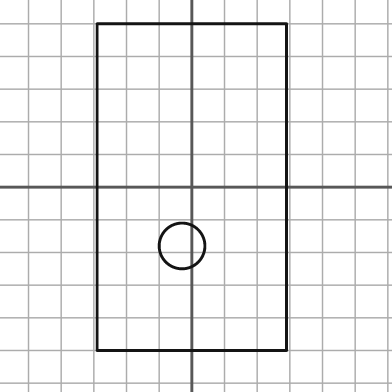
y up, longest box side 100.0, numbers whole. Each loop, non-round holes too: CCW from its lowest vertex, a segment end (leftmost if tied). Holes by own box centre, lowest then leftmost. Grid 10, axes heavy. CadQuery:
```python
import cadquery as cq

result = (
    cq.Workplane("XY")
    .moveTo(-29.0, -50.0)
    .lineTo(29.0, -50.0)
    .lineTo(29.0, 50.0)
    .lineTo(-29.0, 50.0)
    .close()
    .moveTo(-3.0, -18.0)
    .circle(7.0)
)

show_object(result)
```